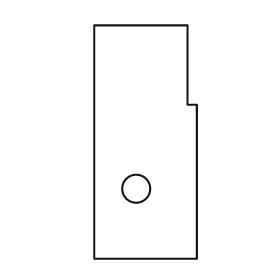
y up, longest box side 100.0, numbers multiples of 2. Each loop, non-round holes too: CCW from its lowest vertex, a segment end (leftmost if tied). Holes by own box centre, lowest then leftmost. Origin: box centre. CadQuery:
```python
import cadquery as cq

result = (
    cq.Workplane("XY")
    .moveTo(-22.0, -50.0)
    .lineTo(22.0, -50.0)
    .lineTo(22.0, 16.0)
    .lineTo(18.0, 16.0)
    .lineTo(18.0, 50.0)
    .lineTo(-22.0, 50.0)
    .close()
    .moveTo(-4.0, -20.0)
    .circle(6.0)
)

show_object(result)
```